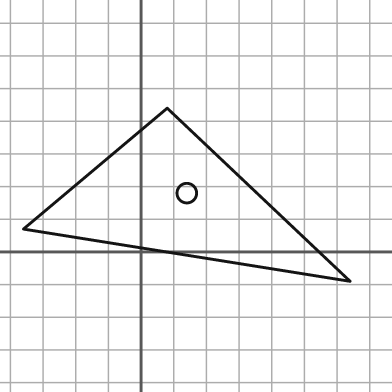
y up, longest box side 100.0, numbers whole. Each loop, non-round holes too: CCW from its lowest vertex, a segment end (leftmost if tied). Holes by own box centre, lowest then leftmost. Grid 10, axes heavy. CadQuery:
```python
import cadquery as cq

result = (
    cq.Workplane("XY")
    .moveTo(64.0, -9.0)
    .lineTo(8.0, 44.0)
    .lineTo(-36.0, 7.0)
    .close()
    .moveTo(14.0, 18.0)
    .circle(3.0)
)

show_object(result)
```